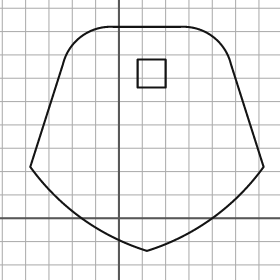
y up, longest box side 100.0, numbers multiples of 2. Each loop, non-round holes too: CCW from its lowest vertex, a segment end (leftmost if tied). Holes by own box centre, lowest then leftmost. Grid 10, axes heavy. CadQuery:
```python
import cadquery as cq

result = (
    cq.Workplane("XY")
    .moveTo(12.0, -14.0)
    .threePointArc((40.0, 0.0), (62.0, 22.0))
    .lineTo(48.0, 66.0)
    .threePointArc((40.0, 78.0), (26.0, 82.0))
    .lineTo(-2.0, 82.0)
    .threePointArc((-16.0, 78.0), (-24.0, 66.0))
    .lineTo(-38.0, 22.0)
    .threePointArc((-16.0, 0.0), (12.0, -14.0))
    .close()
    .moveTo(8.0, 56.0)
    .lineTo(20.0, 56.0)
    .lineTo(20.0, 68.0)
    .lineTo(8.0, 68.0)
    .close()
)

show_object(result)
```